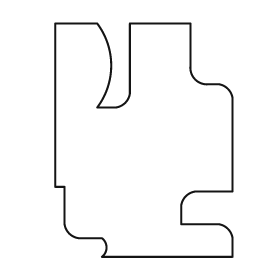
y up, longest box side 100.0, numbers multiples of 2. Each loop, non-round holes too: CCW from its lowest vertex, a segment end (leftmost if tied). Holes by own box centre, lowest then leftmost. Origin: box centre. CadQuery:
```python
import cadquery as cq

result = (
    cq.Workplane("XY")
    .moveTo(-18.0, -50.0)
    .lineTo(38.0, -50.0)
    .lineTo(38.0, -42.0)
    .threePointArc((36.0, -38.0), (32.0, -36.0))
    .lineTo(16.0, -36.0)
    .lineTo(16.0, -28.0)
    .threePointArc((18.0, -24.0), (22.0, -22.0))
    .lineTo(38.0, -22.0)
    .lineTo(38.0, 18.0)
    .threePointArc((36.0, 22.0), (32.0, 24.0))
    .lineTo(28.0, 24.0)
    .threePointArc((22.0, 26.0), (20.0, 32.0))
    .lineTo(20.0, 50.0)
    .lineTo(-6.0, 50.0)
    .lineTo(-6.0, 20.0)
    .threePointArc((-8.0, 16.0), (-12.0, 14.0))
    .lineTo(-20.0, 14.0)
    .threePointArc((-14.0, 32.0), (-20.0, 50.0))
    .lineTo(-38.0, 50.0)
    .lineTo(-38.0, -20.0)
    .lineTo(-34.0, -20.0)
    .lineTo(-34.0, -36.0)
    .threePointArc((-32.0, -40.0), (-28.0, -42.0))
    .lineTo(-18.0, -42.0)
    .threePointArc((-16.0, -46.0), (-18.0, -50.0))
    .close()
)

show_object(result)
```